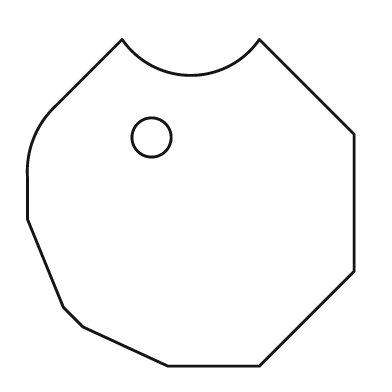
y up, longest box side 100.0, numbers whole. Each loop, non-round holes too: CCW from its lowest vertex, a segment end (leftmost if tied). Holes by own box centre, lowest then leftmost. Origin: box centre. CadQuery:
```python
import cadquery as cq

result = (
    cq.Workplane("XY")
    .moveTo(-7.0, -50.0)
    .lineTo(21.0, -50.0)
    .lineTo(50.0, -21.0)
    .lineTo(50.0, 21.0)
    .lineTo(21.0, 50.0)
    .threePointArc((0.0, 39.0), (-21.0, 50.0))
    .lineTo(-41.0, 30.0)
    .threePointArc((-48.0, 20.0), (-50.0, 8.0))
    .lineTo(-50.0, -5.0)
    .lineTo(-39.0, -32.0)
    .lineTo(-33.0, -38.0)
    .close()
    .moveTo(-12.0, 20.0)
    .circle(6.0)
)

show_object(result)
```